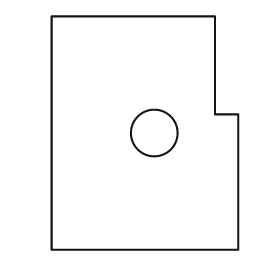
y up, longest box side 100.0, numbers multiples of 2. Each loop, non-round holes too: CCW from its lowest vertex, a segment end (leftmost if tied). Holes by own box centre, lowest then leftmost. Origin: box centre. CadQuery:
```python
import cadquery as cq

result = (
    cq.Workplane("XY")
    .moveTo(-40.0, -50.0)
    .lineTo(40.0, -50.0)
    .lineTo(40.0, 8.0)
    .lineTo(30.0, 8.0)
    .lineTo(30.0, 50.0)
    .lineTo(-40.0, 50.0)
    .close()
    .moveTo(4.0, 0.0)
    .circle(10.0)
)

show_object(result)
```